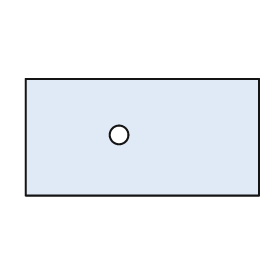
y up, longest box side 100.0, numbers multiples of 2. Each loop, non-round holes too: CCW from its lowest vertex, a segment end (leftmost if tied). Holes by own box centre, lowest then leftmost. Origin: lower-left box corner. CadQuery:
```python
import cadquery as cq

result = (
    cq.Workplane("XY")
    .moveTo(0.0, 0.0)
    .lineTo(100.0, 0.0)
    .lineTo(100.0, 50.0)
    .lineTo(0.0, 50.0)
    .close()
    .moveTo(40.0, 26.0)
    .circle(4.0)
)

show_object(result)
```